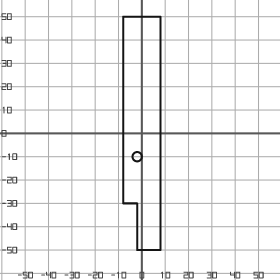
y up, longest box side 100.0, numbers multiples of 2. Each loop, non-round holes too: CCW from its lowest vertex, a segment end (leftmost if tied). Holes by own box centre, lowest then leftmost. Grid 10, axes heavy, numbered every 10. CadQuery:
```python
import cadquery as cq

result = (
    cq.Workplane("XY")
    .moveTo(-2.0, -50.0)
    .lineTo(8.0, -50.0)
    .lineTo(8.0, 50.0)
    .lineTo(-8.0, 50.0)
    .lineTo(-8.0, -30.0)
    .lineTo(-2.0, -30.0)
    .close()
    .moveTo(-2.0, -10.0)
    .circle(2.0)
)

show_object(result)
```